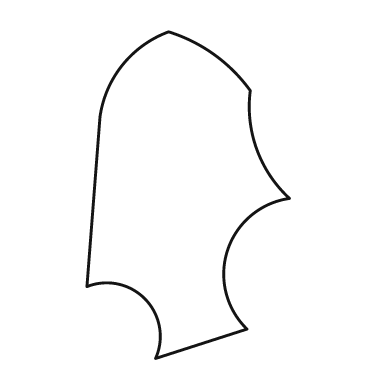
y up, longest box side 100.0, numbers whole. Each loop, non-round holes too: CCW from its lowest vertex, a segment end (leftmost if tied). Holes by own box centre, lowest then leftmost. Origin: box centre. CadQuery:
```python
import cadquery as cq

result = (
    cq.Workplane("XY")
    .moveTo(-10.0, -50.0)
    .lineTo(18.0, -41.0)
    .threePointArc((12.0, -17.0), (31.0, -1.0))
    .threePointArc((21.0, 14.0), (19.0, 32.0))
    .threePointArc((8.0, 43.0), (-6.0, 50.0))
    .threePointArc((-20.0, 40.0), (-27.0, 24.0))
    .lineTo(-31.0, -28.0)
    .threePointArc((-13.0, -32.0), (-10.0, -50.0))
    .close()
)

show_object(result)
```